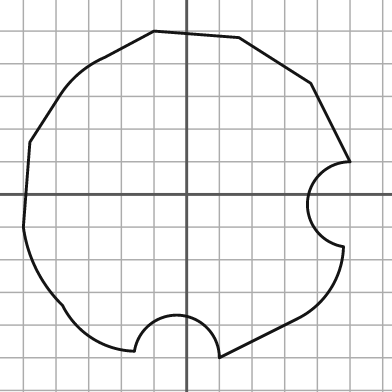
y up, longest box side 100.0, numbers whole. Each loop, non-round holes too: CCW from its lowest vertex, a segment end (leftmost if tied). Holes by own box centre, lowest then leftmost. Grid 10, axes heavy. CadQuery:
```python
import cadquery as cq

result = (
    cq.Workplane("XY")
    .moveTo(10.0, -50.0)
    .lineTo(34.0, -38.0)
    .threePointArc((44.0, -29.0), (48.0, -16.0))
    .threePointArc((37.0, -2.0), (50.0, 10.0))
    .lineTo(38.0, 34.0)
    .lineTo(16.0, 48.0)
    .lineTo(-10.0, 50.0)
    .lineTo(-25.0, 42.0)
    .threePointArc((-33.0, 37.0), (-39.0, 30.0))
    .lineTo(-48.0, 16.0)
    .lineTo(-50.0, -10.0)
    .threePointArc((-46.0, -23.0), (-38.0, -34.0))
    .threePointArc((-29.0, -44.0), (-16.0, -48.0))
    .threePointArc((-2.0, -37.0), (10.0, -50.0))
    .close()
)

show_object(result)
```